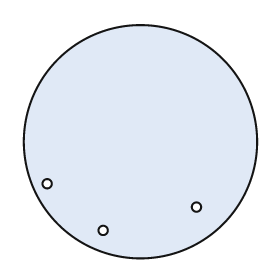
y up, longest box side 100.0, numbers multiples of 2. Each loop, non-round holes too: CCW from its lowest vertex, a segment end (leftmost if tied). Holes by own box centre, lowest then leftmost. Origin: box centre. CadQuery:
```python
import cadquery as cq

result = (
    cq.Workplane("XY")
    .moveTo(0.0, 0.0)
    .circle(50.0)
    .moveTo(-16.0, -38.0)
    .circle(2.0)
    .moveTo(24.0, -28.0)
    .circle(2.0)
    .moveTo(-40.0, -18.0)
    .circle(2.0)
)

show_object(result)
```